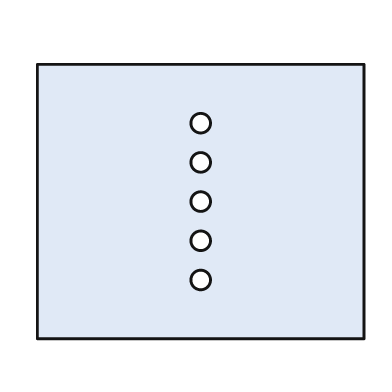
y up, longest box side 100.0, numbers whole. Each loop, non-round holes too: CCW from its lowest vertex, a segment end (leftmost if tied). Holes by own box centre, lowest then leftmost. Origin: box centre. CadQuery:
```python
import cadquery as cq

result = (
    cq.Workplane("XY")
    .moveTo(-50.0, -42.0)
    .lineTo(50.0, -42.0)
    .lineTo(50.0, 42.0)
    .lineTo(-50.0, 42.0)
    .close()
    .moveTo(0.0, -24.0)
    .circle(3.0)
    .moveTo(0.0, -12.0)
    .circle(3.0)
    .moveTo(0.0, 0.0)
    .circle(3.0)
    .moveTo(0.0, 12.0)
    .circle(3.0)
    .moveTo(0.0, 24.0)
    .circle(3.0)
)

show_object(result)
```